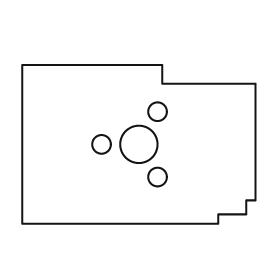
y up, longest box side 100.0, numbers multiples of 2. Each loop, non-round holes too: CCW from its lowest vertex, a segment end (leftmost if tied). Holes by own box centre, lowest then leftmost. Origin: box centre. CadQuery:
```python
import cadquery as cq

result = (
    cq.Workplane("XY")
    .moveTo(-50.0, -34.0)
    .lineTo(34.0, -34.0)
    .lineTo(34.0, -30.0)
    .lineTo(46.0, -30.0)
    .lineTo(46.0, -24.0)
    .lineTo(50.0, -24.0)
    .lineTo(50.0, 26.0)
    .lineTo(10.0, 26.0)
    .lineTo(10.0, 34.0)
    .lineTo(-50.0, 34.0)
    .close()
    .moveTo(8.0, -14.0)
    .circle(4.0)
    .moveTo(-16.0, 0.0)
    .circle(4.0)
    .moveTo(0.0, 0.0)
    .circle(8.0)
    .moveTo(8.0, 14.0)
    .circle(4.0)
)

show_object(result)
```